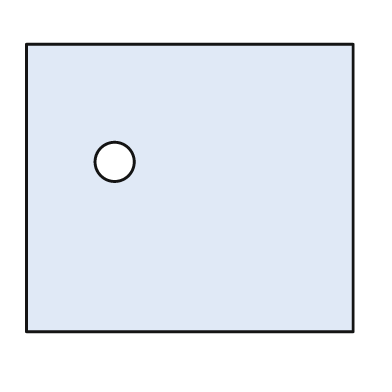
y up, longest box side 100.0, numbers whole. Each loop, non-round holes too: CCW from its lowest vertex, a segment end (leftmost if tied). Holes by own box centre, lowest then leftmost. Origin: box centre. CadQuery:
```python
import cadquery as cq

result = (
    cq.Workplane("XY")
    .moveTo(-50.0, -44.0)
    .lineTo(50.0, -44.0)
    .lineTo(50.0, 44.0)
    .lineTo(-50.0, 44.0)
    .close()
    .moveTo(-23.0, 8.0)
    .circle(6.0)
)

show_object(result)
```